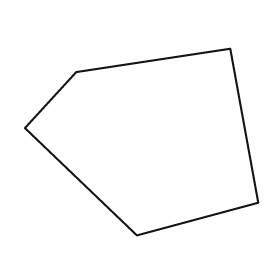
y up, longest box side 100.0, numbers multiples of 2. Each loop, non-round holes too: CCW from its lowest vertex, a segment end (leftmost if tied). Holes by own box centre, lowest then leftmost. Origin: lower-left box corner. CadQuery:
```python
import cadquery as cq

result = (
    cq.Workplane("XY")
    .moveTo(48.0, 0.0)
    .lineTo(100.0, 14.0)
    .lineTo(88.0, 80.0)
    .lineTo(22.0, 70.0)
    .lineTo(0.0, 46.0)
    .close()
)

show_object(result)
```